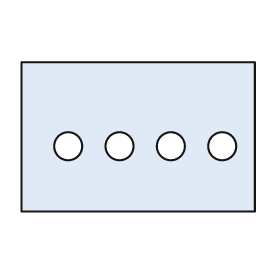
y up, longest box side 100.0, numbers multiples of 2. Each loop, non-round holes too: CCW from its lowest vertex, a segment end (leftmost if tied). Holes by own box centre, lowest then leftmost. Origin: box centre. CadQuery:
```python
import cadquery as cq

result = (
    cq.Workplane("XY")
    .moveTo(-50.0, -32.0)
    .lineTo(50.0, -32.0)
    .lineTo(50.0, 32.0)
    .lineTo(-50.0, 32.0)
    .close()
    .moveTo(-30.0, -4.0)
    .circle(6.0)
    .moveTo(-8.0, -4.0)
    .circle(6.0)
    .moveTo(14.0, -4.0)
    .circle(6.0)
    .moveTo(36.0, -4.0)
    .circle(6.0)
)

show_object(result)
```